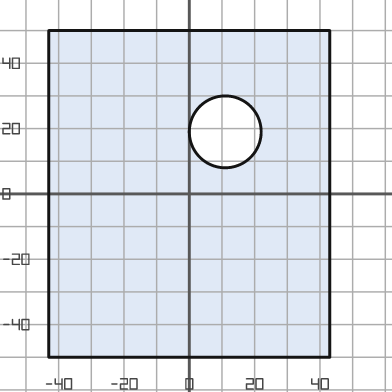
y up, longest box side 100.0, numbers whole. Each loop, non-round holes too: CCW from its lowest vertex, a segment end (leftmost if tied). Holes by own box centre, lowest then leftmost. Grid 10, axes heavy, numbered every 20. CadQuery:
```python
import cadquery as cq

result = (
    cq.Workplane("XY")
    .moveTo(-43.0, -50.0)
    .lineTo(43.0, -50.0)
    .lineTo(43.0, 50.0)
    .lineTo(-43.0, 50.0)
    .close()
    .moveTo(11.0, 19.0)
    .circle(11.0)
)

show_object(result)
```